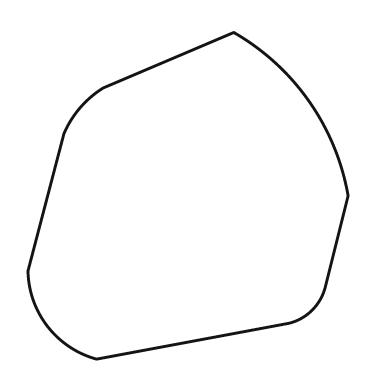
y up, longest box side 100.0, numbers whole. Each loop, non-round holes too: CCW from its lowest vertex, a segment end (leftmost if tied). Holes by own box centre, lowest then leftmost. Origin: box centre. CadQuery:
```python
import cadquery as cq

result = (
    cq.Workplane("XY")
    .moveTo(-28.0, -50.0)
    .lineTo(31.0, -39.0)
    .threePointArc((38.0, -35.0), (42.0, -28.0))
    .lineTo(49.0, 0.0)
    .threePointArc((37.0, 29.0), (14.0, 50.0))
    .lineTo(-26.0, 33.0)
    .threePointArc((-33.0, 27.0), (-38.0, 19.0))
    .lineTo(-49.0, -23.0)
    .threePointArc((-43.0, -40.0), (-28.0, -50.0))
    .close()
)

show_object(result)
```